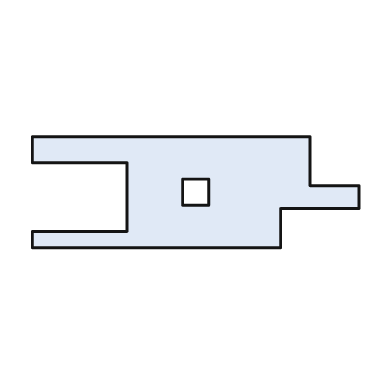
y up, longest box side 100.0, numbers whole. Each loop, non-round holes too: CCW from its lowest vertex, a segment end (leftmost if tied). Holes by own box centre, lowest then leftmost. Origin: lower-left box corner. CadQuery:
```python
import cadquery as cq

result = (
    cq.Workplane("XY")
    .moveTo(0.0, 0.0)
    .lineTo(76.0, 0.0)
    .lineTo(76.0, 12.0)
    .lineTo(100.0, 12.0)
    .lineTo(100.0, 19.0)
    .lineTo(85.0, 19.0)
    .lineTo(85.0, 34.0)
    .lineTo(0.0, 34.0)
    .lineTo(0.0, 26.0)
    .lineTo(29.0, 26.0)
    .lineTo(29.0, 5.0)
    .lineTo(0.0, 5.0)
    .close()
    .moveTo(46.0, 13.0)
    .lineTo(54.0, 13.0)
    .lineTo(54.0, 21.0)
    .lineTo(46.0, 21.0)
    .close()
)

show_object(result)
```